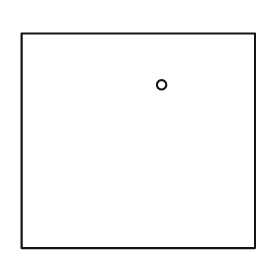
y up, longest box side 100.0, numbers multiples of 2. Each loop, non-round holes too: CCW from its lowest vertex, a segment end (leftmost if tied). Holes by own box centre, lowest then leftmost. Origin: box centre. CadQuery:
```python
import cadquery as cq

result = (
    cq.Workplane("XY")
    .moveTo(-50.0, -46.0)
    .lineTo(50.0, -46.0)
    .lineTo(50.0, 46.0)
    .lineTo(-50.0, 46.0)
    .close()
    .moveTo(10.0, 24.0)
    .circle(2.0)
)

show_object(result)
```